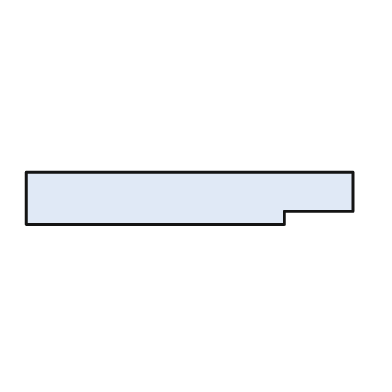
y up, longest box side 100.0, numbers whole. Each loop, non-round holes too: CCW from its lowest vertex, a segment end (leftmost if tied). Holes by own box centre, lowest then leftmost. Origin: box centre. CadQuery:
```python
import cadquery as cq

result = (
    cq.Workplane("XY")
    .moveTo(-50.0, -8.0)
    .lineTo(29.0, -8.0)
    .lineTo(29.0, -4.0)
    .lineTo(50.0, -4.0)
    .lineTo(50.0, 8.0)
    .lineTo(-50.0, 8.0)
    .close()
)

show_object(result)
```